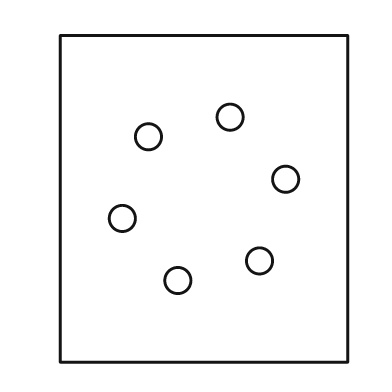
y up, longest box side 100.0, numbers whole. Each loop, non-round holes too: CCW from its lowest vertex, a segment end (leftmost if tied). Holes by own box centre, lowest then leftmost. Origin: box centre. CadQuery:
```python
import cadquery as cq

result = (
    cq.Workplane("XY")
    .moveTo(-44.0, -50.0)
    .lineTo(44.0, -50.0)
    .lineTo(44.0, 50.0)
    .lineTo(-44.0, 50.0)
    .close()
    .moveTo(-8.0, -25.0)
    .circle(4.0)
    .moveTo(17.0, -19.0)
    .circle(4.0)
    .moveTo(-25.0, -6.0)
    .circle(4.0)
    .moveTo(25.0, 6.0)
    .circle(4.0)
    .moveTo(-17.0, 19.0)
    .circle(4.0)
    .moveTo(8.0, 25.0)
    .circle(4.0)
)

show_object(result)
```